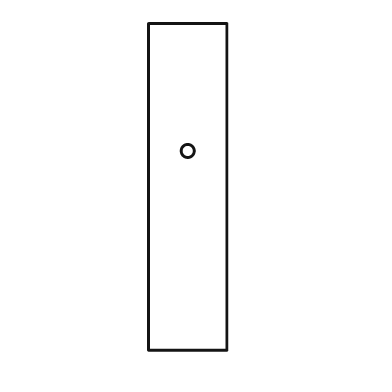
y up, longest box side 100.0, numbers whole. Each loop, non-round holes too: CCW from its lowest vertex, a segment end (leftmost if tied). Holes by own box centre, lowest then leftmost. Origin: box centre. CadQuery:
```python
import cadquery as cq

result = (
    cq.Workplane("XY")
    .moveTo(-12.0, -50.0)
    .lineTo(12.0, -50.0)
    .lineTo(12.0, 50.0)
    .lineTo(-12.0, 50.0)
    .close()
    .moveTo(0.0, 11.0)
    .circle(2.0)
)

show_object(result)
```